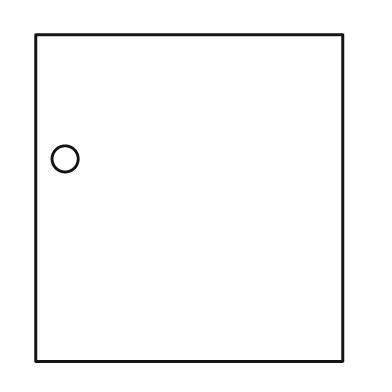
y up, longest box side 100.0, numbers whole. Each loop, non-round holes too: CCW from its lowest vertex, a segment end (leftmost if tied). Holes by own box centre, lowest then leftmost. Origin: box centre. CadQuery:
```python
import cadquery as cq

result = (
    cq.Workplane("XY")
    .moveTo(-47.0, -50.0)
    .lineTo(47.0, -50.0)
    .lineTo(47.0, 50.0)
    .lineTo(-47.0, 50.0)
    .close()
    .moveTo(-38.0, 12.0)
    .circle(4.0)
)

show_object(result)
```